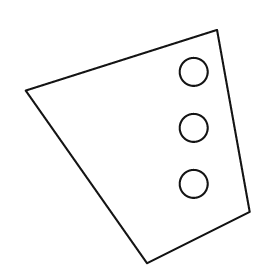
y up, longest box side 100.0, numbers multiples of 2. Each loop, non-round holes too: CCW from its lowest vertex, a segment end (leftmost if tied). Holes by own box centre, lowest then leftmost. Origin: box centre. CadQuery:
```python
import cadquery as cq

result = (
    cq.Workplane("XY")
    .moveTo(4.0, -50.0)
    .lineTo(48.0, -28.0)
    .lineTo(34.0, 50.0)
    .lineTo(-48.0, 24.0)
    .close()
    .moveTo(24.0, -16.0)
    .circle(6.0)
    .moveTo(24.0, 8.0)
    .circle(6.0)
    .moveTo(24.0, 32.0)
    .circle(6.0)
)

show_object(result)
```